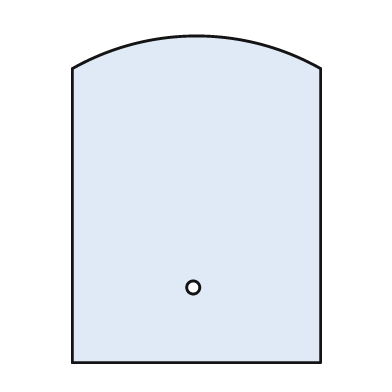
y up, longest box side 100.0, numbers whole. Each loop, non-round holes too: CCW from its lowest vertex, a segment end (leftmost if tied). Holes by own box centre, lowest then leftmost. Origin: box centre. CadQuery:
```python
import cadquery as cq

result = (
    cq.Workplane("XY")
    .moveTo(-38.0, -50.0)
    .lineTo(38.0, -50.0)
    .lineTo(38.0, 40.0)
    .threePointArc((0.0, 50.0), (-38.0, 40.0))
    .close()
    .moveTo(-1.0, -27.0)
    .circle(2.0)
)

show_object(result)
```